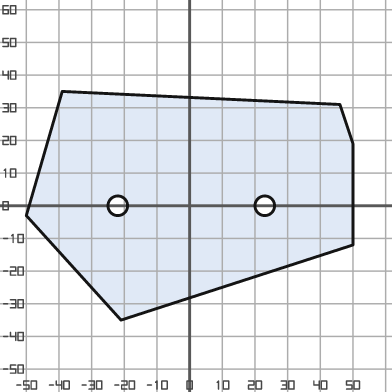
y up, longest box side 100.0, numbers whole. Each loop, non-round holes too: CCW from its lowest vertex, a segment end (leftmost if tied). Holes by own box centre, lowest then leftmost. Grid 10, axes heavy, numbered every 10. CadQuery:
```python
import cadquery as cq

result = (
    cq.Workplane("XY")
    .moveTo(-21.0, -35.0)
    .lineTo(50.0, -12.0)
    .lineTo(50.0, 19.0)
    .lineTo(46.0, 31.0)
    .lineTo(-39.0, 35.0)
    .lineTo(-50.0, -3.0)
    .close()
    .moveTo(-22.0, 0.0)
    .circle(3.0)
    .moveTo(23.0, 0.0)
    .circle(3.0)
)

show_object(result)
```